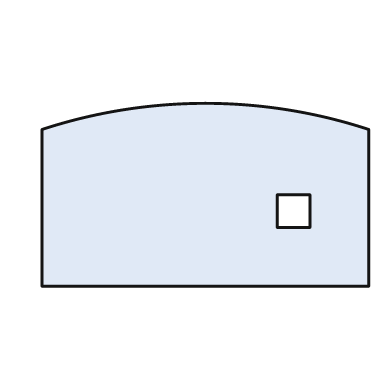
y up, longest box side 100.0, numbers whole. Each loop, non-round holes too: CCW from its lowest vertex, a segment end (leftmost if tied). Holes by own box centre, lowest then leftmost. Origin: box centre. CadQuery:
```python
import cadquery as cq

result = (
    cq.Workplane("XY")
    .moveTo(-50.0, -28.0)
    .lineTo(50.0, -28.0)
    .lineTo(50.0, 20.0)
    .threePointArc((0.0, 28.0), (-50.0, 20.0))
    .close()
    .moveTo(22.0, -10.0)
    .lineTo(32.0, -10.0)
    .lineTo(32.0, 0.0)
    .lineTo(22.0, 0.0)
    .close()
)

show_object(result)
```